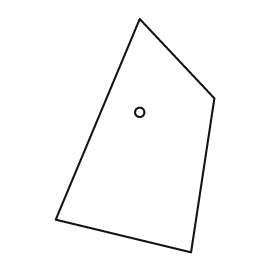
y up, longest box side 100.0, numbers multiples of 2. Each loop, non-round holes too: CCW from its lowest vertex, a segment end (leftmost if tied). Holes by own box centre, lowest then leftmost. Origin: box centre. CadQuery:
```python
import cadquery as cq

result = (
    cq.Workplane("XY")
    .moveTo(24.0, -50.0)
    .lineTo(34.0, 16.0)
    .lineTo(2.0, 50.0)
    .lineTo(-34.0, -36.0)
    .close()
    .moveTo(2.0, 10.0)
    .circle(2.0)
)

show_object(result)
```